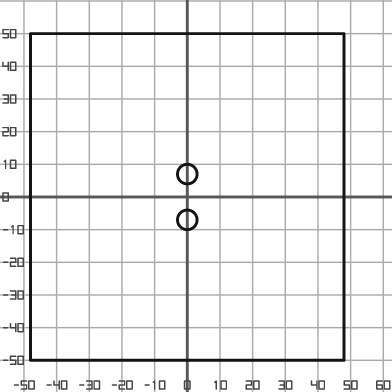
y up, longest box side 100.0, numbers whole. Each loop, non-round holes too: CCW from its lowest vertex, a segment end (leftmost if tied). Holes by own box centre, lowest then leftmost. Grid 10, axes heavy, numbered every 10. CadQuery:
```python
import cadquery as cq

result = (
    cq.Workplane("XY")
    .moveTo(-48.0, -50.0)
    .lineTo(48.0, -50.0)
    .lineTo(48.0, 50.0)
    .lineTo(-48.0, 50.0)
    .close()
    .moveTo(0.0, -7.0)
    .circle(3.0)
    .moveTo(0.0, 7.0)
    .circle(3.0)
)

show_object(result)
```